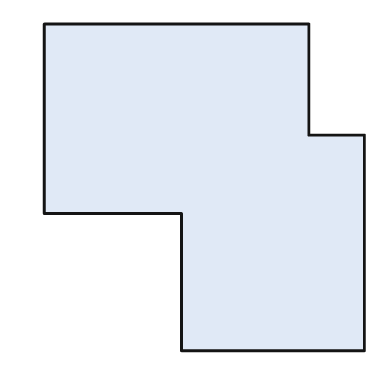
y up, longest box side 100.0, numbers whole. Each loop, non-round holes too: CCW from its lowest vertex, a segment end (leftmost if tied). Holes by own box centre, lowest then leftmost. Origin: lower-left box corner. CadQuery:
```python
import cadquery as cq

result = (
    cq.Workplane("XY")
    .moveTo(42.0, 0.0)
    .lineTo(98.0, 0.0)
    .lineTo(98.0, 66.0)
    .lineTo(81.0, 66.0)
    .lineTo(81.0, 100.0)
    .lineTo(0.0, 100.0)
    .lineTo(0.0, 42.0)
    .lineTo(42.0, 42.0)
    .close()
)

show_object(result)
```